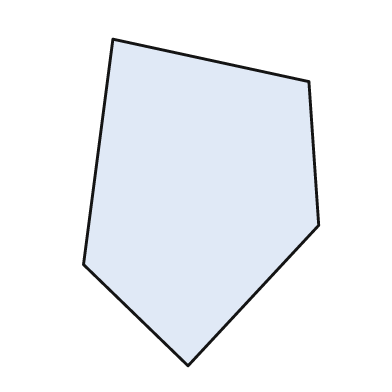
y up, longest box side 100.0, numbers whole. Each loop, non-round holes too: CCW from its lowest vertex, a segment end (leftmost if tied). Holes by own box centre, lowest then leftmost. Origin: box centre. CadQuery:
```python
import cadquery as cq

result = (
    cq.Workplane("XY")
    .moveTo(-4.0, -50.0)
    .lineTo(36.0, -7.0)
    .lineTo(33.0, 37.0)
    .lineTo(-27.0, 50.0)
    .lineTo(-36.0, -19.0)
    .close()
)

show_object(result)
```